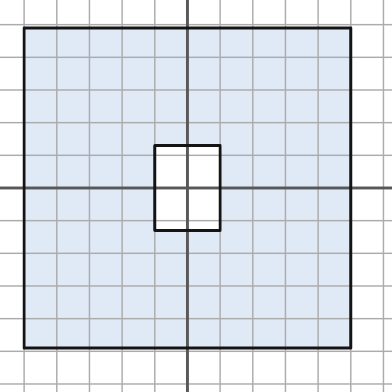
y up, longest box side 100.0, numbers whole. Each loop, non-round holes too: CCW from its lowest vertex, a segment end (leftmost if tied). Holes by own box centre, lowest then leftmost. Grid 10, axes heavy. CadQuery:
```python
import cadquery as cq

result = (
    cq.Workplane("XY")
    .moveTo(-50.0, -49.0)
    .lineTo(50.0, -49.0)
    .lineTo(50.0, 49.0)
    .lineTo(-50.0, 49.0)
    .close()
    .moveTo(-10.0, -13.0)
    .lineTo(10.0, -13.0)
    .lineTo(10.0, 13.0)
    .lineTo(-10.0, 13.0)
    .close()
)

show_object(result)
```